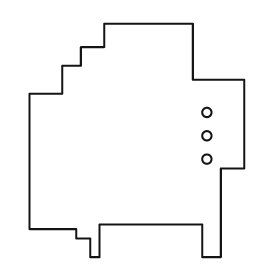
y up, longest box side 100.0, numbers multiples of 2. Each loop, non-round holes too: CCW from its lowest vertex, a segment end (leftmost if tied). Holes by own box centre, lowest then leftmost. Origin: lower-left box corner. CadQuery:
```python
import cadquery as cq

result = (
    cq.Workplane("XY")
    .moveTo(26.0, 0.0)
    .lineTo(30.0, 0.0)
    .lineTo(30.0, 14.0)
    .lineTo(74.0, 14.0)
    .lineTo(74.0, 0.0)
    .lineTo(82.0, 0.0)
    .lineTo(82.0, 38.0)
    .lineTo(92.0, 38.0)
    .lineTo(92.0, 76.0)
    .lineTo(70.0, 76.0)
    .lineTo(70.0, 100.0)
    .lineTo(32.0, 100.0)
    .lineTo(32.0, 90.0)
    .lineTo(22.0, 90.0)
    .lineTo(22.0, 82.0)
    .lineTo(14.0, 82.0)
    .lineTo(14.0, 70.0)
    .lineTo(0.0, 70.0)
    .lineTo(0.0, 12.0)
    .lineTo(20.0, 12.0)
    .lineTo(20.0, 8.0)
    .lineTo(26.0, 8.0)
    .close()
    .moveTo(76.0, 42.0)
    .circle(2.0)
    .moveTo(76.0, 52.0)
    .circle(2.0)
    .moveTo(76.0, 62.0)
    .circle(2.0)
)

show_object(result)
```